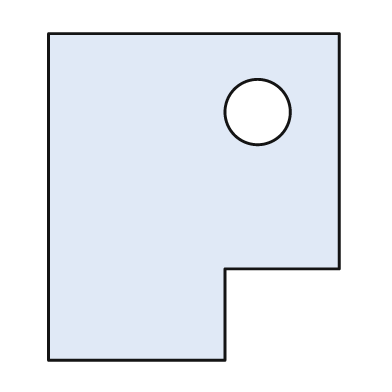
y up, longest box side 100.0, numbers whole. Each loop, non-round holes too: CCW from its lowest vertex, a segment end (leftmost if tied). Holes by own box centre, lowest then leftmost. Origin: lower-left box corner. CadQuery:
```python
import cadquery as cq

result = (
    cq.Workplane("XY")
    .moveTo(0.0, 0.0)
    .lineTo(54.0, 0.0)
    .lineTo(54.0, 28.0)
    .lineTo(89.0, 28.0)
    .lineTo(89.0, 100.0)
    .lineTo(0.0, 100.0)
    .close()
    .moveTo(64.0, 76.0)
    .circle(10.0)
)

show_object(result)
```